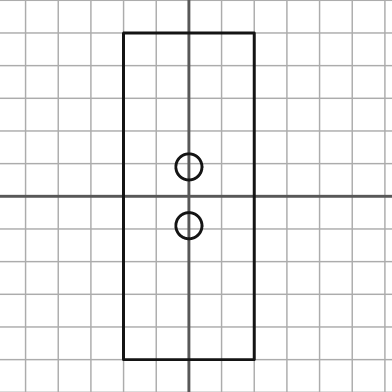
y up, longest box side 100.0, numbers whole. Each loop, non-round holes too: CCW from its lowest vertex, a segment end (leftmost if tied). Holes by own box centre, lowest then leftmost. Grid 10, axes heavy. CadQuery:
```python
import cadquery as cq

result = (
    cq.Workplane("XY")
    .moveTo(-20.0, -50.0)
    .lineTo(20.0, -50.0)
    .lineTo(20.0, 50.0)
    .lineTo(-20.0, 50.0)
    .close()
    .moveTo(0.0, -9.0)
    .circle(4.0)
    .moveTo(0.0, 9.0)
    .circle(4.0)
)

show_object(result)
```